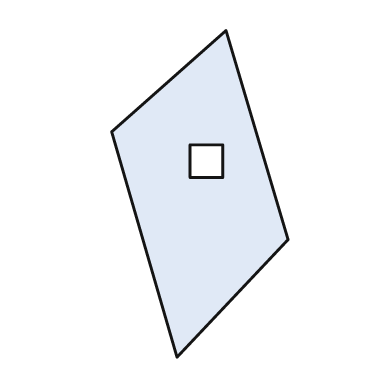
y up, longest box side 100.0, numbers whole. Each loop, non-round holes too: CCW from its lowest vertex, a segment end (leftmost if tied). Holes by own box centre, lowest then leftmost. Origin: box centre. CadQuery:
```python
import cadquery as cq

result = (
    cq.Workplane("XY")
    .moveTo(-7.0, -50.0)
    .lineTo(27.0, -14.0)
    .lineTo(8.0, 50.0)
    .lineTo(-27.0, 19.0)
    .close()
    .moveTo(-3.0, 5.0)
    .lineTo(7.0, 5.0)
    .lineTo(7.0, 15.0)
    .lineTo(-3.0, 15.0)
    .close()
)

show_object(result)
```